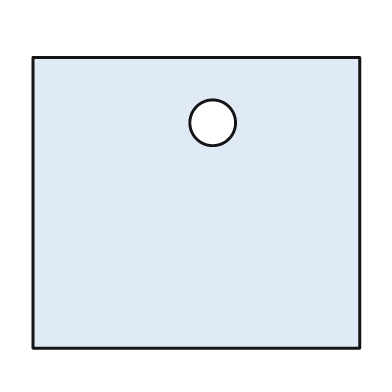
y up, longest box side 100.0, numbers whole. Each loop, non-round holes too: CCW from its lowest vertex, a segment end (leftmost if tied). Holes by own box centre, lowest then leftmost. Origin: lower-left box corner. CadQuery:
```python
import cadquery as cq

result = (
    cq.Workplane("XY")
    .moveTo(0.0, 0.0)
    .lineTo(100.0, 0.0)
    .lineTo(100.0, 89.0)
    .lineTo(0.0, 89.0)
    .close()
    .moveTo(55.0, 69.0)
    .circle(7.0)
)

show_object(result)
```